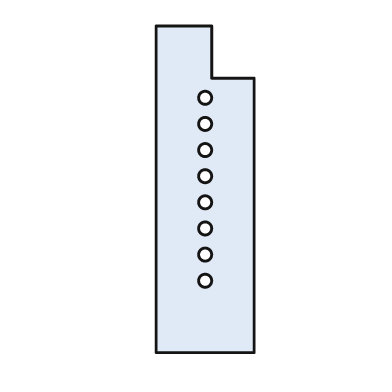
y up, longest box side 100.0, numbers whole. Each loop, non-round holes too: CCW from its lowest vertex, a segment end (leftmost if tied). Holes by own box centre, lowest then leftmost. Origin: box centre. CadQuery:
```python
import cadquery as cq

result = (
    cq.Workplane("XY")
    .moveTo(-15.0, -50.0)
    .lineTo(15.0, -50.0)
    .lineTo(15.0, 34.0)
    .lineTo(2.0, 34.0)
    .lineTo(2.0, 50.0)
    .lineTo(-15.0, 50.0)
    .close()
    .moveTo(0.0, -28.0)
    .circle(2.0)
    .moveTo(0.0, -20.0)
    .circle(2.0)
    .moveTo(0.0, -12.0)
    .circle(2.0)
    .moveTo(0.0, -4.0)
    .circle(2.0)
    .moveTo(0.0, 4.0)
    .circle(2.0)
    .moveTo(0.0, 12.0)
    .circle(2.0)
    .moveTo(0.0, 20.0)
    .circle(2.0)
    .moveTo(0.0, 28.0)
    .circle(2.0)
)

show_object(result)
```